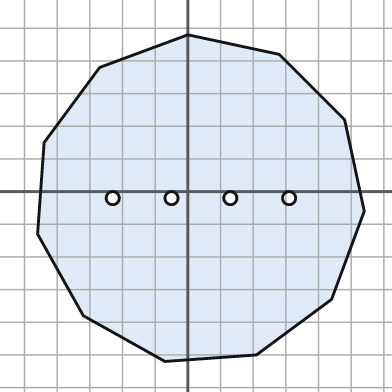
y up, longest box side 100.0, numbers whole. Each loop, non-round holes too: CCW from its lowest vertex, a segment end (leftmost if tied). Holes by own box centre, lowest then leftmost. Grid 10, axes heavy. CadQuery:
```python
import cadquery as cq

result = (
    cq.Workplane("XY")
    .moveTo(-7.0, -52.0)
    .lineTo(21.0, -50.0)
    .lineTo(44.0, -33.0)
    .lineTo(54.0, -6.0)
    .lineTo(48.0, 22.0)
    .lineTo(28.0, 42.0)
    .lineTo(0.0, 48.0)
    .lineTo(-27.0, 38.0)
    .lineTo(-44.0, 15.0)
    .lineTo(-46.0, -13.0)
    .lineTo(-32.0, -38.0)
    .close()
    .moveTo(-23.0, -2.0)
    .circle(2.0)
    .moveTo(-5.0, -2.0)
    .circle(2.0)
    .moveTo(13.0, -2.0)
    .circle(2.0)
    .moveTo(31.0, -2.0)
    .circle(2.0)
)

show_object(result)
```